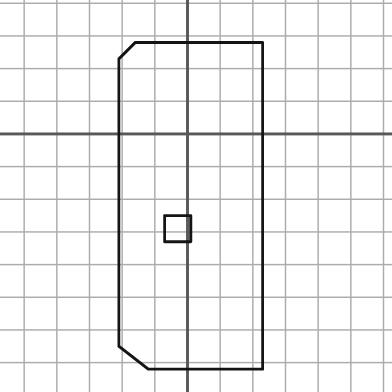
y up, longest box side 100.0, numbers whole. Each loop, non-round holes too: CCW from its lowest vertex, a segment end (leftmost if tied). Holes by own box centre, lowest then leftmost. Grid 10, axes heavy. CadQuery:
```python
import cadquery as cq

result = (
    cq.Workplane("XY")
    .moveTo(-12.0, -72.0)
    .lineTo(23.0, -72.0)
    .lineTo(23.0, 28.0)
    .lineTo(-16.0, 28.0)
    .lineTo(-21.0, 23.0)
    .lineTo(-21.0, -65.0)
    .close()
    .moveTo(-7.0, -33.0)
    .lineTo(1.0, -33.0)
    .lineTo(1.0, -25.0)
    .lineTo(-7.0, -25.0)
    .close()
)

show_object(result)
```